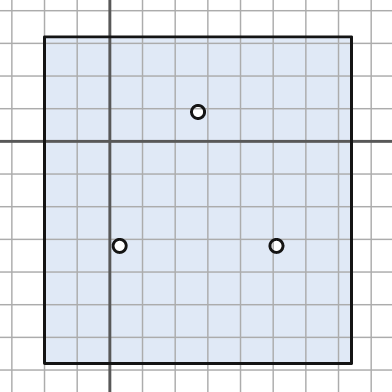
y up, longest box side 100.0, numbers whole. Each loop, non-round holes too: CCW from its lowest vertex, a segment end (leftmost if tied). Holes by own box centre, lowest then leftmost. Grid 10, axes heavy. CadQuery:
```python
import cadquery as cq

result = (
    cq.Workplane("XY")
    .moveTo(-20.0, -68.0)
    .lineTo(74.0, -68.0)
    .lineTo(74.0, 32.0)
    .lineTo(-20.0, 32.0)
    .close()
    .moveTo(3.0, -32.0)
    .circle(2.0)
    .moveTo(51.0, -32.0)
    .circle(2.0)
    .moveTo(27.0, 9.0)
    .circle(2.0)
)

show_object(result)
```